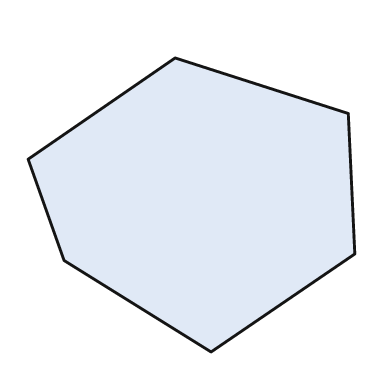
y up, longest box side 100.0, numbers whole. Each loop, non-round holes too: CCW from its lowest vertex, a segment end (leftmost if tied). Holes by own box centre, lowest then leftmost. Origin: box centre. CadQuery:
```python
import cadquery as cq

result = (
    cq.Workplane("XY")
    .moveTo(6.0, -45.0)
    .lineTo(50.0, -15.0)
    .lineTo(48.0, 28.0)
    .lineTo(-5.0, 45.0)
    .lineTo(-50.0, 14.0)
    .lineTo(-39.0, -17.0)
    .close()
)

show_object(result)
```